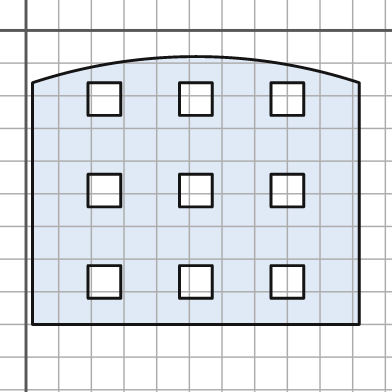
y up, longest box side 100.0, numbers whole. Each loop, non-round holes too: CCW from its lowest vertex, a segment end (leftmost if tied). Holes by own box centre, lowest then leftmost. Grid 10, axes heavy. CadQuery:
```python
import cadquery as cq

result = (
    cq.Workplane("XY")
    .moveTo(2.0, -90.0)
    .lineTo(102.0, -90.0)
    .lineTo(102.0, -16.0)
    .threePointArc((52.0, -8.0), (2.0, -16.0))
    .close()
    .moveTo(19.0, -82.0)
    .lineTo(29.0, -82.0)
    .lineTo(29.0, -72.0)
    .lineTo(19.0, -72.0)
    .close()
    .moveTo(47.0, -82.0)
    .lineTo(57.0, -82.0)
    .lineTo(57.0, -72.0)
    .lineTo(47.0, -72.0)
    .close()
    .moveTo(75.0, -82.0)
    .lineTo(85.0, -82.0)
    .lineTo(85.0, -72.0)
    .lineTo(75.0, -72.0)
    .close()
    .moveTo(19.0, -54.0)
    .lineTo(29.0, -54.0)
    .lineTo(29.0, -44.0)
    .lineTo(19.0, -44.0)
    .close()
    .moveTo(47.0, -54.0)
    .lineTo(57.0, -54.0)
    .lineTo(57.0, -44.0)
    .lineTo(47.0, -44.0)
    .close()
    .moveTo(75.0, -54.0)
    .lineTo(85.0, -54.0)
    .lineTo(85.0, -44.0)
    .lineTo(75.0, -44.0)
    .close()
    .moveTo(19.0, -26.0)
    .lineTo(29.0, -26.0)
    .lineTo(29.0, -16.0)
    .lineTo(19.0, -16.0)
    .close()
    .moveTo(47.0, -26.0)
    .lineTo(57.0, -26.0)
    .lineTo(57.0, -16.0)
    .lineTo(47.0, -16.0)
    .close()
    .moveTo(75.0, -26.0)
    .lineTo(85.0, -26.0)
    .lineTo(85.0, -16.0)
    .lineTo(75.0, -16.0)
    .close()
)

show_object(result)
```